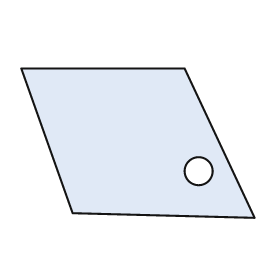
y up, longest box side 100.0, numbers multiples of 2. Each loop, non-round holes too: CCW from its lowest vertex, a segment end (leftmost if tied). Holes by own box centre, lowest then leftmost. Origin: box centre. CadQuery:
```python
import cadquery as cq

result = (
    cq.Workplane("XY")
    .moveTo(50.0, -32.0)
    .lineTo(20.0, 32.0)
    .lineTo(-50.0, 32.0)
    .lineTo(-28.0, -30.0)
    .close()
    .moveTo(26.0, -12.0)
    .circle(6.0)
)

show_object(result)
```